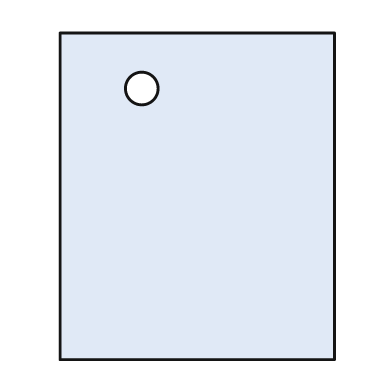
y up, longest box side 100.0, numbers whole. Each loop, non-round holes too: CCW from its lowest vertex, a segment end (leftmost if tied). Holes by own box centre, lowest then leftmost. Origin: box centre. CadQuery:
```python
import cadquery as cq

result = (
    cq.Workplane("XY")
    .moveTo(-42.0, -50.0)
    .lineTo(42.0, -50.0)
    .lineTo(42.0, 50.0)
    .lineTo(-42.0, 50.0)
    .close()
    .moveTo(-17.0, 33.0)
    .circle(5.0)
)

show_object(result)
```